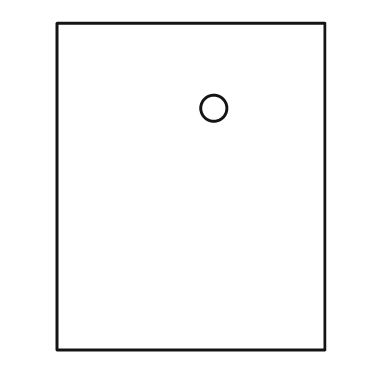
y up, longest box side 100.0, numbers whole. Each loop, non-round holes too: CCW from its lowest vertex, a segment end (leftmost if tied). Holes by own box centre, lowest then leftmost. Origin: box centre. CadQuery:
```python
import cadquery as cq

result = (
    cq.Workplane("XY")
    .moveTo(-41.0, -50.0)
    .lineTo(41.0, -50.0)
    .lineTo(41.0, 50.0)
    .lineTo(-41.0, 50.0)
    .close()
    .moveTo(7.0, 24.0)
    .circle(4.0)
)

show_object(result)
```